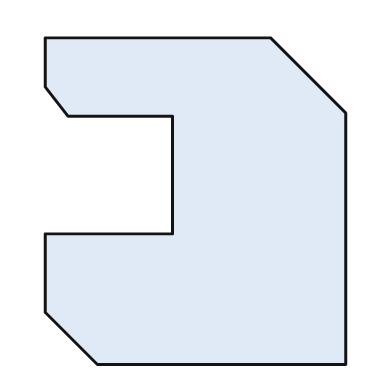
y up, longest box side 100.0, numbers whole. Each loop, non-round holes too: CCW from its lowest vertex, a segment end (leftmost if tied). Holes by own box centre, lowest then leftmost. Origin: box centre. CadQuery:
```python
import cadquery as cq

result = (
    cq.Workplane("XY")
    .moveTo(-30.0, -50.0)
    .lineTo(46.0, -50.0)
    .lineTo(46.0, 27.0)
    .lineTo(23.0, 50.0)
    .lineTo(-46.0, 50.0)
    .lineTo(-46.0, 35.0)
    .lineTo(-39.0, 26.0)
    .lineTo(-7.0, 26.0)
    .lineTo(-7.0, -10.0)
    .lineTo(-46.0, -10.0)
    .lineTo(-46.0, -34.0)
    .close()
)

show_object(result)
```